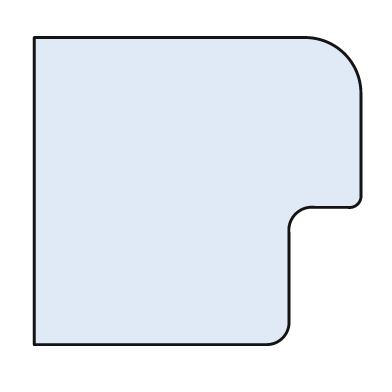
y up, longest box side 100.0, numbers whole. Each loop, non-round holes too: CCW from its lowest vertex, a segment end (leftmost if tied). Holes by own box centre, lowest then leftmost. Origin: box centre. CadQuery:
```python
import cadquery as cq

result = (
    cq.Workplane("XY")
    .moveTo(-50.0, -47.0)
    .lineTo(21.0, -47.0)
    .threePointArc((26.0, -45.0), (28.0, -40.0))
    .lineTo(28.0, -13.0)
    .threePointArc((30.0, -7.0), (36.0, -5.0))
    .lineTo(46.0, -5.0)
    .threePointArc((49.0, -4.0), (50.0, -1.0))
    .lineTo(50.0, 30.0)
    .threePointArc((45.0, 42.0), (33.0, 47.0))
    .lineTo(-50.0, 47.0)
    .close()
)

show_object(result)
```